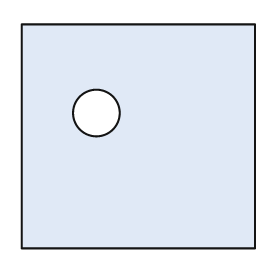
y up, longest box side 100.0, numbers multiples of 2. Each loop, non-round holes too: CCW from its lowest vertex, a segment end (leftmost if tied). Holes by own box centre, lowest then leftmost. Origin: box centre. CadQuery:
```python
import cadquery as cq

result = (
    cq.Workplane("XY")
    .moveTo(-50.0, -48.0)
    .lineTo(50.0, -48.0)
    .lineTo(50.0, 48.0)
    .lineTo(-50.0, 48.0)
    .close()
    .moveTo(-18.0, 10.0)
    .circle(10.0)
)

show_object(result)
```